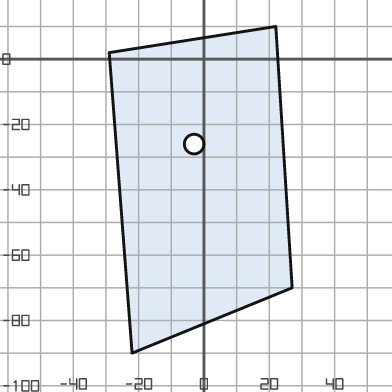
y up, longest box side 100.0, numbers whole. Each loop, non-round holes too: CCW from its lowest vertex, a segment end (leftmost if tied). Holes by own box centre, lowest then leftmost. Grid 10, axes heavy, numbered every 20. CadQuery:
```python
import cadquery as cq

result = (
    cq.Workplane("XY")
    .moveTo(-22.0, -90.0)
    .lineTo(27.0, -70.0)
    .lineTo(22.0, 10.0)
    .lineTo(-29.0, 2.0)
    .close()
    .moveTo(-3.0, -26.0)
    .circle(3.0)
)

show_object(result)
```